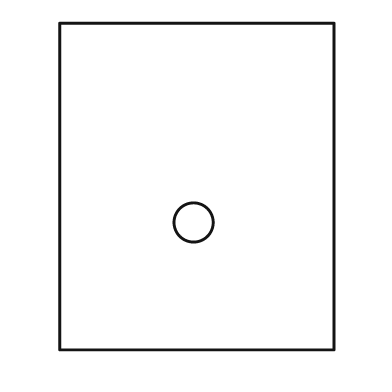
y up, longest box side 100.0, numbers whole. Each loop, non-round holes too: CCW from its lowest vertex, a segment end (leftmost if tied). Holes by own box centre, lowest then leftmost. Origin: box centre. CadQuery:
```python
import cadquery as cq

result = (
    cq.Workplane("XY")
    .moveTo(-42.0, -50.0)
    .lineTo(42.0, -50.0)
    .lineTo(42.0, 50.0)
    .lineTo(-42.0, 50.0)
    .close()
    .moveTo(-1.0, -11.0)
    .circle(6.0)
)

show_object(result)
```